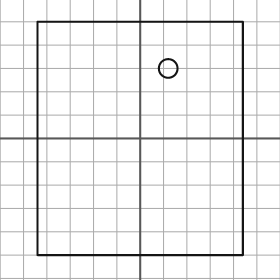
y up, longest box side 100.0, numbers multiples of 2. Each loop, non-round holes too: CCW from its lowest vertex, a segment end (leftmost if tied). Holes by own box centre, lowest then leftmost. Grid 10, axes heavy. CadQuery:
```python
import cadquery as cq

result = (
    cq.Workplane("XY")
    .moveTo(-44.0, -50.0)
    .lineTo(44.0, -50.0)
    .lineTo(44.0, 50.0)
    .lineTo(-44.0, 50.0)
    .close()
    .moveTo(12.0, 30.0)
    .circle(4.0)
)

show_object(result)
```